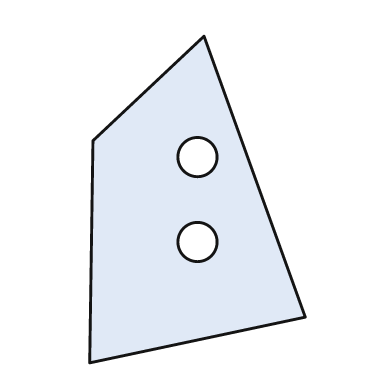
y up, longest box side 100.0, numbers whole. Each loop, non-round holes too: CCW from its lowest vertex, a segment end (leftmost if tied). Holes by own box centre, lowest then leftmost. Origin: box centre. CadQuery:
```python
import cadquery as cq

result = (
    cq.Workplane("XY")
    .moveTo(-33.0, -50.0)
    .lineTo(33.0, -36.0)
    .lineTo(2.0, 50.0)
    .lineTo(-32.0, 18.0)
    .close()
    .moveTo(0.0, -13.0)
    .circle(6.0)
    .moveTo(0.0, 13.0)
    .circle(6.0)
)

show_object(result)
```